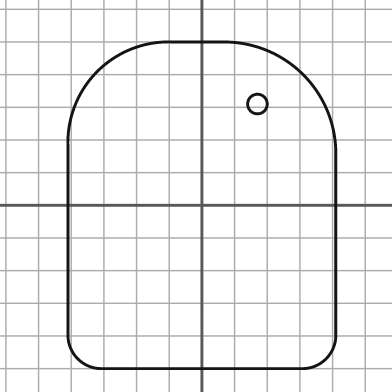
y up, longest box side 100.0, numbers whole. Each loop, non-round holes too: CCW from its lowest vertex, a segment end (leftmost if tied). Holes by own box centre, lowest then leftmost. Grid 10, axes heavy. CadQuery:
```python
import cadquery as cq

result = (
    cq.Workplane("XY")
    .moveTo(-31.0, -50.0)
    .lineTo(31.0, -50.0)
    .threePointArc((38.0, -47.0), (41.0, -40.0))
    .lineTo(41.0, 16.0)
    .threePointArc((31.0, 40.0), (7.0, 50.0))
    .lineTo(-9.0, 50.0)
    .threePointArc((-32.0, 41.0), (-41.0, 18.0))
    .lineTo(-41.0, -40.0)
    .threePointArc((-38.0, -47.0), (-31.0, -50.0))
    .close()
    .moveTo(17.0, 31.0)
    .circle(3.0)
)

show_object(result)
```